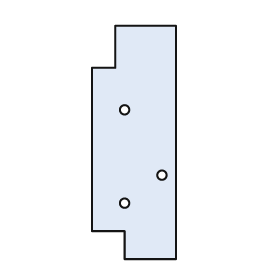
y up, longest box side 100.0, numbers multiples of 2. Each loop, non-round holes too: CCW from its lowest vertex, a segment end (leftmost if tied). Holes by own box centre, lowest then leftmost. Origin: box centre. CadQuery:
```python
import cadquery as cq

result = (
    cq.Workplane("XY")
    .moveTo(-4.0, -50.0)
    .lineTo(18.0, -50.0)
    .lineTo(18.0, 50.0)
    .lineTo(-8.0, 50.0)
    .lineTo(-8.0, 32.0)
    .lineTo(-18.0, 32.0)
    .lineTo(-18.0, -38.0)
    .lineTo(-4.0, -38.0)
    .close()
    .moveTo(-4.0, -26.0)
    .circle(2.0)
    .moveTo(12.0, -14.0)
    .circle(2.0)
    .moveTo(-4.0, 14.0)
    .circle(2.0)
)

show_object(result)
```